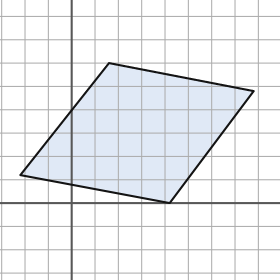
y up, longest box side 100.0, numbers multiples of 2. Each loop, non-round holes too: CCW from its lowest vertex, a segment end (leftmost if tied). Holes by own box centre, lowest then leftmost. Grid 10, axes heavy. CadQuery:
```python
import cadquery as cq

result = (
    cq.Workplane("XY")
    .moveTo(42.0, 0.0)
    .lineTo(78.0, 48.0)
    .lineTo(16.0, 60.0)
    .lineTo(-22.0, 12.0)
    .close()
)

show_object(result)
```